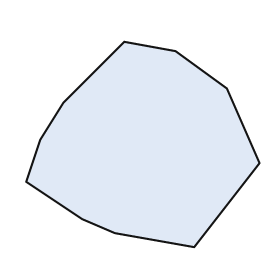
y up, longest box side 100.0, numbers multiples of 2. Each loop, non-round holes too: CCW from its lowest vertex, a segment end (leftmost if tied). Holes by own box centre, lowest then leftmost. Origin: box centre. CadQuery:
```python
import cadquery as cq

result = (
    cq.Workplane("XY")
    .moveTo(22.0, -44.0)
    .lineTo(50.0, -8.0)
    .lineTo(36.0, 24.0)
    .lineTo(14.0, 40.0)
    .lineTo(-8.0, 44.0)
    .lineTo(-34.0, 18.0)
    .lineTo(-44.0, 2.0)
    .lineTo(-50.0, -16.0)
    .lineTo(-26.0, -32.0)
    .lineTo(-12.0, -38.0)
    .close()
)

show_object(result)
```